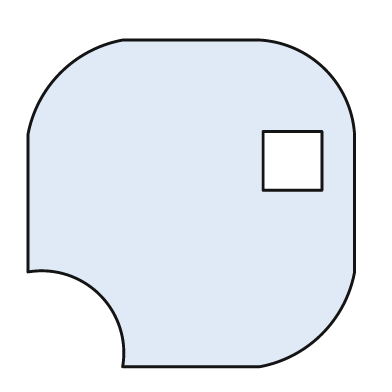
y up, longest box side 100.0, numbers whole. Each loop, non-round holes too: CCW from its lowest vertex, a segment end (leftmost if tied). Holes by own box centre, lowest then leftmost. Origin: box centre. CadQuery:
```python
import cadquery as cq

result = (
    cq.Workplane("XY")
    .moveTo(-21.0, -50.0)
    .lineTo(21.0, -50.0)
    .threePointArc((40.0, -40.0), (50.0, -21.0))
    .lineTo(50.0, 21.0)
    .threePointArc((41.0, 41.0), (21.0, 50.0))
    .lineTo(-21.0, 50.0)
    .threePointArc((-40.0, 40.0), (-50.0, 21.0))
    .lineTo(-50.0, -21.0)
    .threePointArc((-28.0, -28.0), (-21.0, -50.0))
    .close()
    .moveTo(22.0, 4.0)
    .lineTo(40.0, 4.0)
    .lineTo(40.0, 22.0)
    .lineTo(22.0, 22.0)
    .close()
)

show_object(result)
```